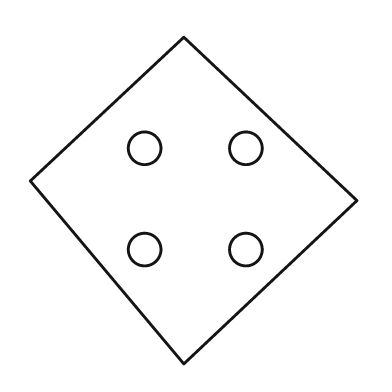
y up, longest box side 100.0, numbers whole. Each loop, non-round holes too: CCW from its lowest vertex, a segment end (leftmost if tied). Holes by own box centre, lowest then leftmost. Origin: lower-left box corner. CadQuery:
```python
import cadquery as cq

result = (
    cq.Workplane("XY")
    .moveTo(47.0, 0.0)
    .lineTo(100.0, 50.0)
    .lineTo(47.0, 100.0)
    .lineTo(0.0, 56.0)
    .close()
    .moveTo(35.0, 35.0)
    .circle(5.0)
    .moveTo(66.0, 35.0)
    .circle(5.0)
    .moveTo(35.0, 66.0)
    .circle(5.0)
    .moveTo(66.0, 66.0)
    .circle(5.0)
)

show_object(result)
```